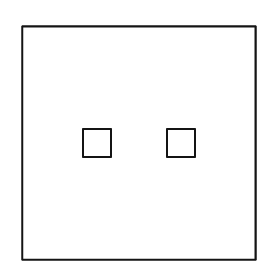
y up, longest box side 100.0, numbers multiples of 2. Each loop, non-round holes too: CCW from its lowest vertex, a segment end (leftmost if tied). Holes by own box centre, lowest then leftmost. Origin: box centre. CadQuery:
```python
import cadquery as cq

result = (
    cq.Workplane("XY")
    .moveTo(-50.0, -50.0)
    .lineTo(50.0, -50.0)
    .lineTo(50.0, 50.0)
    .lineTo(-50.0, 50.0)
    .close()
    .moveTo(-24.0, -6.0)
    .lineTo(-12.0, -6.0)
    .lineTo(-12.0, 6.0)
    .lineTo(-24.0, 6.0)
    .close()
    .moveTo(12.0, -6.0)
    .lineTo(24.0, -6.0)
    .lineTo(24.0, 6.0)
    .lineTo(12.0, 6.0)
    .close()
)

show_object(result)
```